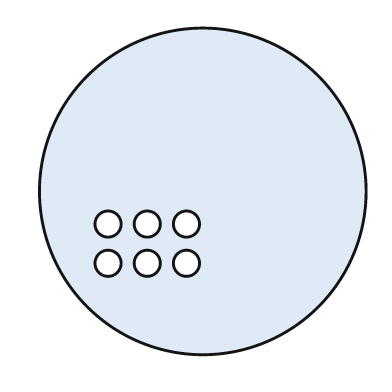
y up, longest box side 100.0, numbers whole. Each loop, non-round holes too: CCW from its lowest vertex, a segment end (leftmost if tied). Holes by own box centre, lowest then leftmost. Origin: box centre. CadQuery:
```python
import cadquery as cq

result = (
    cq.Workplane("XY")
    .moveTo(0.0, 0.0)
    .circle(50.0)
    .moveTo(-29.0, -22.0)
    .circle(4.0)
    .moveTo(-17.0, -22.0)
    .circle(4.0)
    .moveTo(-5.0, -22.0)
    .circle(4.0)
    .moveTo(-29.0, -10.0)
    .circle(4.0)
    .moveTo(-17.0, -10.0)
    .circle(4.0)
    .moveTo(-5.0, -10.0)
    .circle(4.0)
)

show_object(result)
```